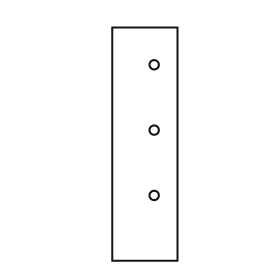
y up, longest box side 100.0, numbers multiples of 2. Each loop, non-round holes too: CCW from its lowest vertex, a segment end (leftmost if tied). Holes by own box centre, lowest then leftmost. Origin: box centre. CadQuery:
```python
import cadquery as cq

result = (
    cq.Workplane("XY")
    .moveTo(-14.0, -50.0)
    .lineTo(14.0, -50.0)
    .lineTo(14.0, 50.0)
    .lineTo(-14.0, 50.0)
    .close()
    .moveTo(4.0, -22.0)
    .circle(2.0)
    .moveTo(4.0, 6.0)
    .circle(2.0)
    .moveTo(4.0, 34.0)
    .circle(2.0)
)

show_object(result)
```